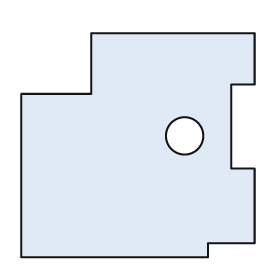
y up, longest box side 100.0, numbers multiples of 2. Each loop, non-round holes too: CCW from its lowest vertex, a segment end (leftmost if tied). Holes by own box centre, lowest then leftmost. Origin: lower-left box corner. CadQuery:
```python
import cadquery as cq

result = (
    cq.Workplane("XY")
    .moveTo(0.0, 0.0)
    .lineTo(80.0, 0.0)
    .lineTo(80.0, 6.0)
    .lineTo(100.0, 6.0)
    .lineTo(100.0, 38.0)
    .lineTo(90.0, 38.0)
    .lineTo(90.0, 74.0)
    .lineTo(100.0, 74.0)
    .lineTo(100.0, 96.0)
    .lineTo(30.0, 96.0)
    .lineTo(30.0, 70.0)
    .lineTo(0.0, 70.0)
    .close()
    .moveTo(70.0, 52.0)
    .circle(8.0)
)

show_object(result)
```